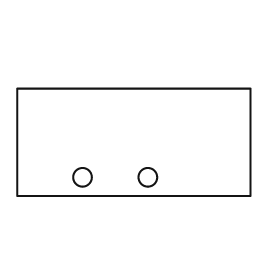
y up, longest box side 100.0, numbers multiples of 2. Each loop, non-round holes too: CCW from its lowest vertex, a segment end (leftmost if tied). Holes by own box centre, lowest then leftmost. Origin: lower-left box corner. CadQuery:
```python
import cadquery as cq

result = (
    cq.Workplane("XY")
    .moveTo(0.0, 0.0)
    .lineTo(100.0, 0.0)
    .lineTo(100.0, 46.0)
    .lineTo(0.0, 46.0)
    .close()
    .moveTo(28.0, 8.0)
    .circle(4.0)
    .moveTo(56.0, 8.0)
    .circle(4.0)
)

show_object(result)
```